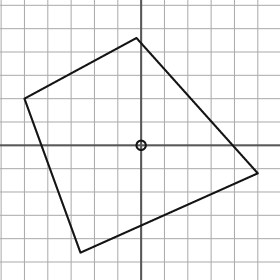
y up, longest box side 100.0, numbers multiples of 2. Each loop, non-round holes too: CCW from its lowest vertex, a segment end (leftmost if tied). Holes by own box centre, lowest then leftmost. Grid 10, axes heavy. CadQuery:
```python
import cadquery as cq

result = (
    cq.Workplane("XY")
    .moveTo(-26.0, -46.0)
    .lineTo(50.0, -12.0)
    .lineTo(-2.0, 46.0)
    .lineTo(-50.0, 20.0)
    .close()
    .moveTo(0.0, 0.0)
    .circle(2.0)
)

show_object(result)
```